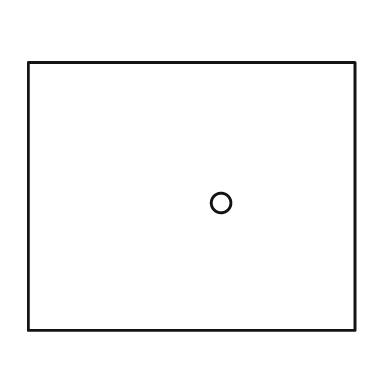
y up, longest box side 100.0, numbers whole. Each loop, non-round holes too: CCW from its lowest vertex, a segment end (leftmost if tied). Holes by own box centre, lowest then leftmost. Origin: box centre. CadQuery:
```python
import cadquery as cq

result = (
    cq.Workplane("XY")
    .moveTo(-50.0, -41.0)
    .lineTo(50.0, -41.0)
    .lineTo(50.0, 41.0)
    .lineTo(-50.0, 41.0)
    .close()
    .moveTo(9.0, -2.0)
    .circle(3.0)
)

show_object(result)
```